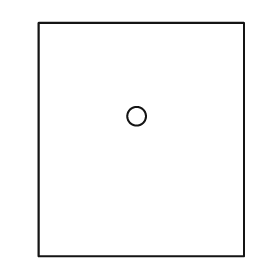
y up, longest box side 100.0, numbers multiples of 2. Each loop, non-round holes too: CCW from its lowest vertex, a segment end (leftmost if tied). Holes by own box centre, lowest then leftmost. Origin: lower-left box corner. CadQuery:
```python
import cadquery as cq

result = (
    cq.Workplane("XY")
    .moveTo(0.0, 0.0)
    .lineTo(88.0, 0.0)
    .lineTo(88.0, 100.0)
    .lineTo(0.0, 100.0)
    .close()
    .moveTo(42.0, 60.0)
    .circle(4.0)
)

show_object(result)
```